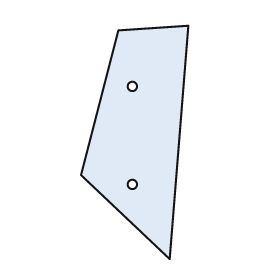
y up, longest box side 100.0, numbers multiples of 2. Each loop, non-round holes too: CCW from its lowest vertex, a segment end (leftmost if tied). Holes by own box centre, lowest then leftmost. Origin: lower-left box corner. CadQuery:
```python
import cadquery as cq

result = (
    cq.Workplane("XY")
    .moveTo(38.0, 0.0)
    .lineTo(46.0, 100.0)
    .lineTo(16.0, 98.0)
    .lineTo(0.0, 36.0)
    .close()
    .moveTo(22.0, 32.0)
    .circle(2.0)
    .moveTo(22.0, 74.0)
    .circle(2.0)
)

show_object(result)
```